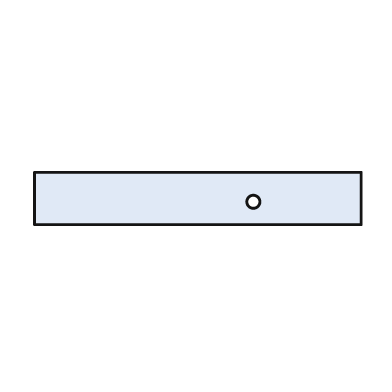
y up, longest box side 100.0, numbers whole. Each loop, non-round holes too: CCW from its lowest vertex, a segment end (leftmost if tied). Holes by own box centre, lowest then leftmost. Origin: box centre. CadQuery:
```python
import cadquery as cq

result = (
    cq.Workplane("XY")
    .moveTo(-50.0, -8.0)
    .lineTo(50.0, -8.0)
    .lineTo(50.0, 8.0)
    .lineTo(-50.0, 8.0)
    .close()
    .moveTo(17.0, -1.0)
    .circle(2.0)
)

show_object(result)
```